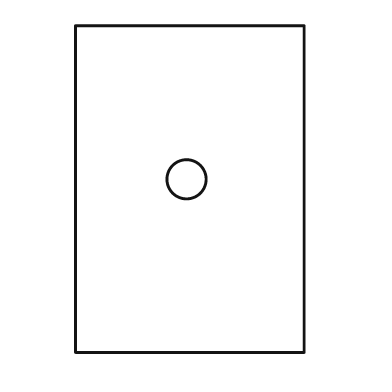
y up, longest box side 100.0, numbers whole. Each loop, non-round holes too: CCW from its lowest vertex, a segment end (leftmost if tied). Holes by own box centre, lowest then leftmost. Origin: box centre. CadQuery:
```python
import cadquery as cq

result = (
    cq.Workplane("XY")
    .moveTo(-35.0, -50.0)
    .lineTo(35.0, -50.0)
    .lineTo(35.0, 50.0)
    .lineTo(-35.0, 50.0)
    .close()
    .moveTo(-1.0, 3.0)
    .circle(6.0)
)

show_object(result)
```